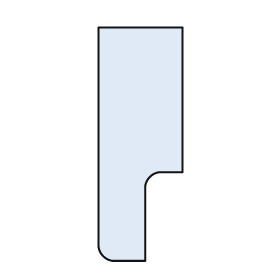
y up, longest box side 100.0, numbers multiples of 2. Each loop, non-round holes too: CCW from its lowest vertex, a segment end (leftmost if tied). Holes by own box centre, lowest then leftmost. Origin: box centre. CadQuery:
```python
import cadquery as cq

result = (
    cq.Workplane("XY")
    .moveTo(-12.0, -50.0)
    .lineTo(2.0, -50.0)
    .lineTo(2.0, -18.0)
    .threePointArc((4.0, -14.0), (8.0, -12.0))
    .lineTo(18.0, -12.0)
    .lineTo(18.0, 50.0)
    .lineTo(-18.0, 50.0)
    .lineTo(-18.0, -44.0)
    .threePointArc((-16.0, -48.0), (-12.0, -50.0))
    .close()
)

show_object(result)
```